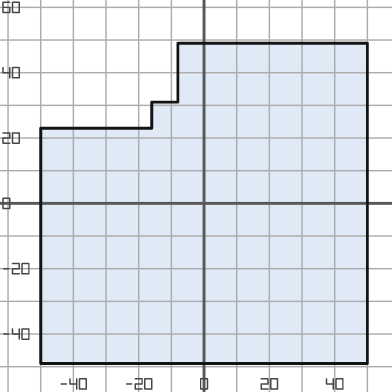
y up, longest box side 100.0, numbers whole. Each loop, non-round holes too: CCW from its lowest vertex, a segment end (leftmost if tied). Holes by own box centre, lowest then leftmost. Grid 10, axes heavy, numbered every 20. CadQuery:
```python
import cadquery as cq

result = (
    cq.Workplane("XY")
    .moveTo(-50.0, -49.0)
    .lineTo(50.0, -49.0)
    .lineTo(50.0, 49.0)
    .lineTo(-8.0, 49.0)
    .lineTo(-8.0, 31.0)
    .lineTo(-16.0, 31.0)
    .lineTo(-16.0, 23.0)
    .lineTo(-50.0, 23.0)
    .close()
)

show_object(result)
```